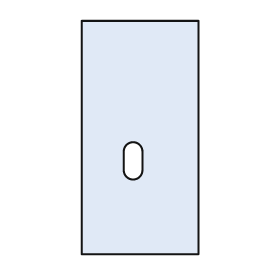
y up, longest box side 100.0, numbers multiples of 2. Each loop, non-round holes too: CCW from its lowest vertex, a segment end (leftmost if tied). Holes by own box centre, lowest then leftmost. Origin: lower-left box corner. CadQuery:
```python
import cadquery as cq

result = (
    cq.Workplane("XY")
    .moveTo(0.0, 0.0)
    .lineTo(50.0, 0.0)
    .lineTo(50.0, 100.0)
    .lineTo(0.0, 100.0)
    .close()
    .moveTo(18.0, 36.0)
    .threePointArc((22.0, 32.0), (26.0, 36.0))
    .lineTo(26.0, 44.0)
    .threePointArc((22.0, 48.0), (18.0, 44.0))
    .close()
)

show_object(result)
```